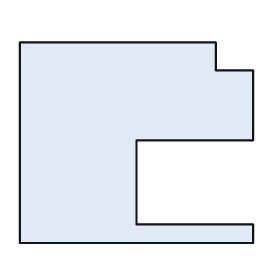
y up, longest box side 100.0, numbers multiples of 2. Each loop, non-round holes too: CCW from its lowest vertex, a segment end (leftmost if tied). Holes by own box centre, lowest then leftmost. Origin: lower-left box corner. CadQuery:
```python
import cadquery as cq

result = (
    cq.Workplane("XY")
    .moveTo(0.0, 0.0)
    .lineTo(100.0, 0.0)
    .lineTo(100.0, 8.0)
    .lineTo(50.0, 8.0)
    .lineTo(50.0, 44.0)
    .lineTo(100.0, 44.0)
    .lineTo(100.0, 74.0)
    .lineTo(84.0, 74.0)
    .lineTo(84.0, 86.0)
    .lineTo(0.0, 86.0)
    .close()
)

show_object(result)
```